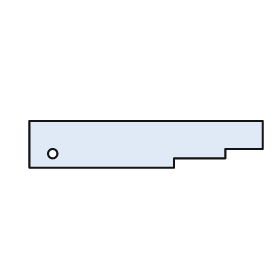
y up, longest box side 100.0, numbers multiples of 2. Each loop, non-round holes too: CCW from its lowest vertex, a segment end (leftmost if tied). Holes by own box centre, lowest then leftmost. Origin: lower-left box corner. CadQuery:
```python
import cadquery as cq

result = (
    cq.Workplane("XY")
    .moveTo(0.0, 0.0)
    .lineTo(62.0, 0.0)
    .lineTo(62.0, 4.0)
    .lineTo(84.0, 4.0)
    .lineTo(84.0, 8.0)
    .lineTo(100.0, 8.0)
    .lineTo(100.0, 20.0)
    .lineTo(0.0, 20.0)
    .close()
    .moveTo(10.0, 6.0)
    .circle(2.0)
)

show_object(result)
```